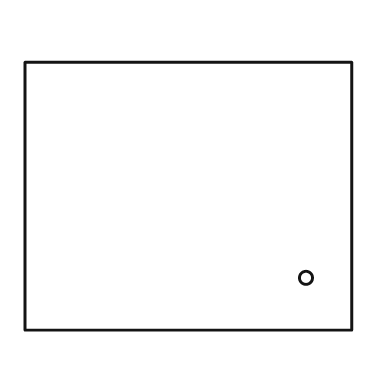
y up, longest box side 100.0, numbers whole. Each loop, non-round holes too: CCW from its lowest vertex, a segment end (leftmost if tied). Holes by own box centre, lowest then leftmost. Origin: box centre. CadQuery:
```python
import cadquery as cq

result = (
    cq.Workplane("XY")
    .moveTo(-50.0, -41.0)
    .lineTo(50.0, -41.0)
    .lineTo(50.0, 41.0)
    .lineTo(-50.0, 41.0)
    .close()
    .moveTo(36.0, -25.0)
    .circle(2.0)
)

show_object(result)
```